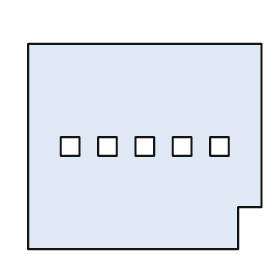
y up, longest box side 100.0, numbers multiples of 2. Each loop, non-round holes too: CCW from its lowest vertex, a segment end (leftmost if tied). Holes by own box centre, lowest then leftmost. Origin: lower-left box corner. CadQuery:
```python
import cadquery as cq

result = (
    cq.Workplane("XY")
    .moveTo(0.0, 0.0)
    .lineTo(90.0, 0.0)
    .lineTo(90.0, 18.0)
    .lineTo(100.0, 18.0)
    .lineTo(100.0, 88.0)
    .lineTo(0.0, 88.0)
    .close()
    .moveTo(14.0, 40.0)
    .lineTo(22.0, 40.0)
    .lineTo(22.0, 48.0)
    .lineTo(14.0, 48.0)
    .close()
    .moveTo(30.0, 40.0)
    .lineTo(38.0, 40.0)
    .lineTo(38.0, 48.0)
    .lineTo(30.0, 48.0)
    .close()
    .moveTo(46.0, 40.0)
    .lineTo(54.0, 40.0)
    .lineTo(54.0, 48.0)
    .lineTo(46.0, 48.0)
    .close()
    .moveTo(62.0, 40.0)
    .lineTo(70.0, 40.0)
    .lineTo(70.0, 48.0)
    .lineTo(62.0, 48.0)
    .close()
    .moveTo(78.0, 40.0)
    .lineTo(86.0, 40.0)
    .lineTo(86.0, 48.0)
    .lineTo(78.0, 48.0)
    .close()
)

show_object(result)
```